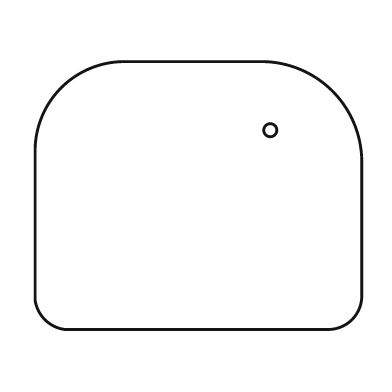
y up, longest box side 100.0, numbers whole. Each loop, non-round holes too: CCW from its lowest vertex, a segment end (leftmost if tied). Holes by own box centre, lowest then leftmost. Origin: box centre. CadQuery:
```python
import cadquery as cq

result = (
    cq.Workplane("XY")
    .moveTo(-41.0, -41.0)
    .lineTo(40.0, -41.0)
    .threePointArc((47.0, -38.0), (50.0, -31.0))
    .lineTo(50.0, 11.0)
    .threePointArc((41.0, 32.0), (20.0, 41.0))
    .lineTo(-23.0, 41.0)
    .threePointArc((-42.0, 33.0), (-50.0, 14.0))
    .lineTo(-50.0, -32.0)
    .threePointArc((-47.0, -38.0), (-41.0, -41.0))
    .close()
    .moveTo(22.0, 20.0)
    .circle(2.0)
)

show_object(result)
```